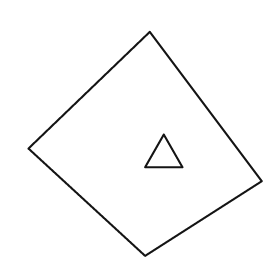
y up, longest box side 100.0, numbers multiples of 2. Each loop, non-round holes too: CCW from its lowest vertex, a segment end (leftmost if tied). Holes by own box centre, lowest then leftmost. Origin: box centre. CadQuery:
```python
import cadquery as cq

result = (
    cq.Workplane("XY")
    .moveTo(0.0, -48.0)
    .lineTo(50.0, -16.0)
    .lineTo(2.0, 48.0)
    .lineTo(-50.0, -2.0)
    .close()
    .moveTo(0.0, -10.0)
    .lineTo(16.0, -10.0)
    .lineTo(8.0, 4.0)
    .close()
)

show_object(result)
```